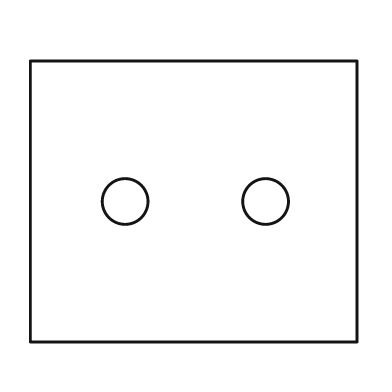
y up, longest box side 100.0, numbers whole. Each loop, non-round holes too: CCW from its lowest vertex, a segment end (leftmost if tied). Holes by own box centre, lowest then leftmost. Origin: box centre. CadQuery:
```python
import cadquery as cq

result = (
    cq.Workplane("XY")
    .moveTo(-50.0, -43.0)
    .lineTo(50.0, -43.0)
    .lineTo(50.0, 43.0)
    .lineTo(-50.0, 43.0)
    .close()
    .moveTo(-21.0, 0.0)
    .circle(7.0)
    .moveTo(22.0, 0.0)
    .circle(7.0)
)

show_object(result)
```